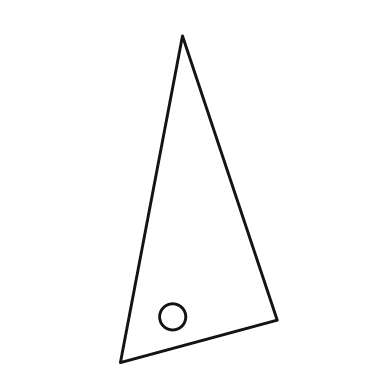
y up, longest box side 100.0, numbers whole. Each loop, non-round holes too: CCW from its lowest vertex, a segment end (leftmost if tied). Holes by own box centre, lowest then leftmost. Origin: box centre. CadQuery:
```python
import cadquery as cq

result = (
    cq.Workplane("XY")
    .moveTo(-24.0, -50.0)
    .lineTo(24.0, -37.0)
    .lineTo(-5.0, 50.0)
    .close()
    .moveTo(-8.0, -36.0)
    .circle(4.0)
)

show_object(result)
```